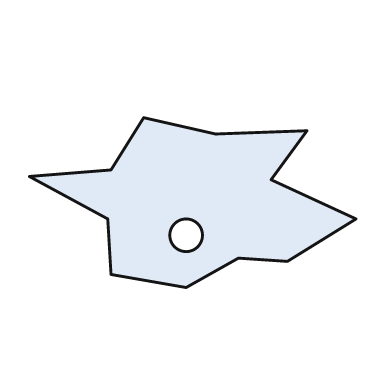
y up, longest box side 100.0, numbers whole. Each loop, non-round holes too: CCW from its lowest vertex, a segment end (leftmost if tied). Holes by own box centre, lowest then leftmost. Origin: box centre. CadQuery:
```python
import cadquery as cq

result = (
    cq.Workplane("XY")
    .moveTo(-2.0, -26.0)
    .lineTo(14.0, -17.0)
    .lineTo(29.0, -18.0)
    .lineTo(50.0, -5.0)
    .lineTo(24.0, 7.0)
    .lineTo(35.0, 22.0)
    .lineTo(7.0, 21.0)
    .lineTo(-15.0, 26.0)
    .lineTo(-25.0, 10.0)
    .lineTo(-50.0, 8.0)
    .lineTo(-26.0, -5.0)
    .lineTo(-25.0, -22.0)
    .close()
    .moveTo(-2.0, -10.0)
    .circle(5.0)
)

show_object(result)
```